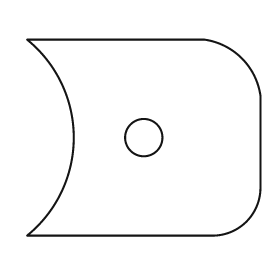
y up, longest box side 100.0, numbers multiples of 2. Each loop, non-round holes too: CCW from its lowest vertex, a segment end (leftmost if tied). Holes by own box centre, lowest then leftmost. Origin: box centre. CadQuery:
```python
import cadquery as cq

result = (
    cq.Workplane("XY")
    .moveTo(-50.0, -42.0)
    .lineTo(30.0, -42.0)
    .threePointArc((44.0, -36.0), (50.0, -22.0))
    .lineTo(50.0, 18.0)
    .threePointArc((42.0, 34.0), (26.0, 42.0))
    .lineTo(-50.0, 42.0)
    .threePointArc((-30.0, 0.0), (-50.0, -42.0))
    .close()
    .moveTo(0.0, 0.0)
    .circle(8.0)
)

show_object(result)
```